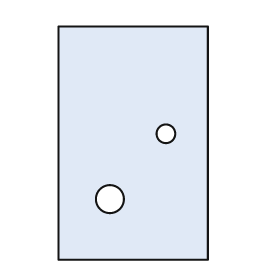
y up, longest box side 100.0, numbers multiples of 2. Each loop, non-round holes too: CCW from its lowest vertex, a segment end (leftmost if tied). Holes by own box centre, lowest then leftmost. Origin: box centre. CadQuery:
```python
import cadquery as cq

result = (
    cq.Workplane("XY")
    .moveTo(-32.0, -50.0)
    .lineTo(32.0, -50.0)
    .lineTo(32.0, 50.0)
    .lineTo(-32.0, 50.0)
    .close()
    .moveTo(-10.0, -24.0)
    .circle(6.0)
    .moveTo(14.0, 4.0)
    .circle(4.0)
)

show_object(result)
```